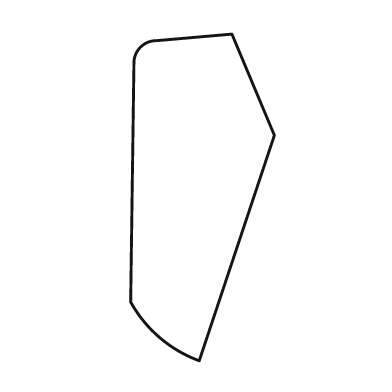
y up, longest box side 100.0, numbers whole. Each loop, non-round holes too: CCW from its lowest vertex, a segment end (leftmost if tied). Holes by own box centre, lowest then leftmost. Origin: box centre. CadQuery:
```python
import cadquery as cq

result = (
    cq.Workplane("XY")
    .moveTo(-1.0, -50.0)
    .lineTo(22.0, 19.0)
    .lineTo(9.0, 50.0)
    .lineTo(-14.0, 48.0)
    .threePointArc((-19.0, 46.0), (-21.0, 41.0))
    .lineTo(-22.0, -32.0)
    .threePointArc((-13.0, -43.0), (-1.0, -50.0))
    .close()
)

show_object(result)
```